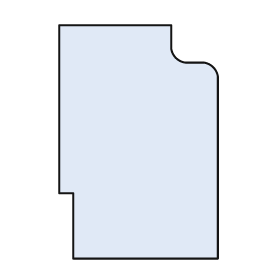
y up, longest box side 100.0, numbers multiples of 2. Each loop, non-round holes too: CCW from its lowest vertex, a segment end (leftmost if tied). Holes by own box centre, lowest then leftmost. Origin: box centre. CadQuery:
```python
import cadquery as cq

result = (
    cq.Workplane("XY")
    .moveTo(-28.0, -50.0)
    .lineTo(34.0, -50.0)
    .lineTo(34.0, 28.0)
    .threePointArc((32.0, 32.0), (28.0, 34.0))
    .lineTo(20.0, 34.0)
    .threePointArc((16.0, 36.0), (14.0, 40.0))
    .lineTo(14.0, 50.0)
    .lineTo(-34.0, 50.0)
    .lineTo(-34.0, -22.0)
    .lineTo(-28.0, -22.0)
    .close()
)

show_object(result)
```